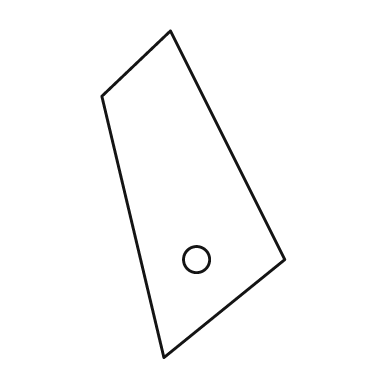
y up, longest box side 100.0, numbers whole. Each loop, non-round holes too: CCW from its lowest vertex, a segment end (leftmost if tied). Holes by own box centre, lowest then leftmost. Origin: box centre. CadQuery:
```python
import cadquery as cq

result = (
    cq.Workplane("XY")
    .moveTo(-9.0, -50.0)
    .lineTo(28.0, -20.0)
    .lineTo(-7.0, 50.0)
    .lineTo(-28.0, 30.0)
    .close()
    .moveTo(1.0, -20.0)
    .circle(4.0)
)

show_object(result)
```